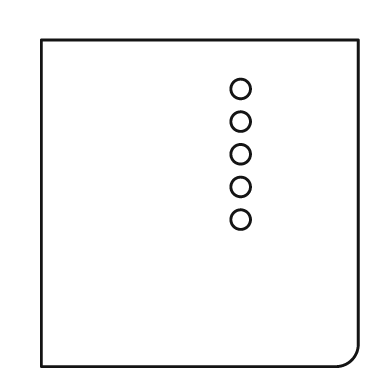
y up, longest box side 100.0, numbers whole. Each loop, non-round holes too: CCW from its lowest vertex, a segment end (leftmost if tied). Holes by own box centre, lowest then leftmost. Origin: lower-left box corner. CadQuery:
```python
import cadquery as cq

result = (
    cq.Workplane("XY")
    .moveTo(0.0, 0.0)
    .lineTo(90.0, 0.0)
    .threePointArc((95.0, 2.0), (97.0, 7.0))
    .lineTo(97.0, 100.0)
    .lineTo(0.0, 100.0)
    .close()
    .moveTo(61.0, 45.0)
    .circle(3.0)
    .moveTo(61.0, 55.0)
    .circle(3.0)
    .moveTo(61.0, 65.0)
    .circle(3.0)
    .moveTo(61.0, 75.0)
    .circle(3.0)
    .moveTo(61.0, 85.0)
    .circle(3.0)
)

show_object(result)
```